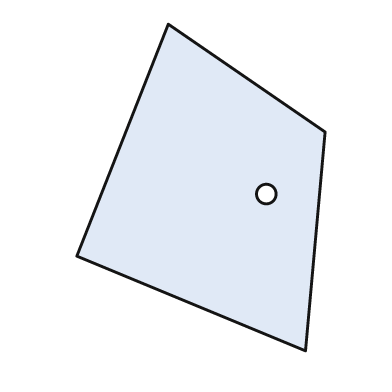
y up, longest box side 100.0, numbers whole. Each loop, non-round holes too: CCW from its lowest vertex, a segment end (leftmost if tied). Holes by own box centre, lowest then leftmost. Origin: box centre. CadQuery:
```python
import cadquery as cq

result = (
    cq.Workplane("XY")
    .moveTo(32.0, -50.0)
    .lineTo(38.0, 17.0)
    .lineTo(-10.0, 50.0)
    .lineTo(-38.0, -21.0)
    .close()
    .moveTo(20.0, -2.0)
    .circle(3.0)
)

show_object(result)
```